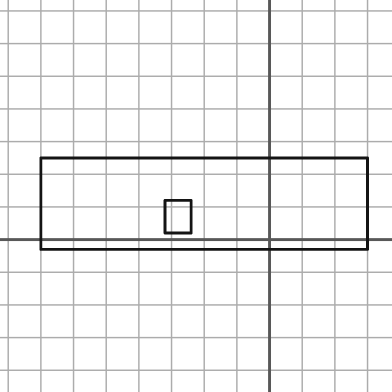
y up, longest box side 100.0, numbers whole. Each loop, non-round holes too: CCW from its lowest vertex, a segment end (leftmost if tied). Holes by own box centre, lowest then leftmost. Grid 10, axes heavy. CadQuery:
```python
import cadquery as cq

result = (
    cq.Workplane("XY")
    .moveTo(-70.0, -3.0)
    .lineTo(30.0, -3.0)
    .lineTo(30.0, 25.0)
    .lineTo(-70.0, 25.0)
    .close()
    .moveTo(-32.0, 2.0)
    .lineTo(-24.0, 2.0)
    .lineTo(-24.0, 12.0)
    .lineTo(-32.0, 12.0)
    .close()
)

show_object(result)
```